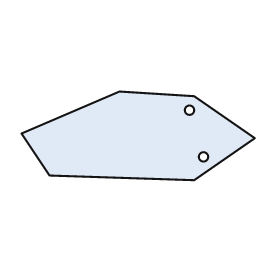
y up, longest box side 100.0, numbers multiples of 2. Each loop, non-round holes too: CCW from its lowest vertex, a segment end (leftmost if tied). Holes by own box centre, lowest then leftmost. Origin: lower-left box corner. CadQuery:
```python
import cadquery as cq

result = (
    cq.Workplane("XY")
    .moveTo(74.0, 0.0)
    .lineTo(100.0, 18.0)
    .lineTo(74.0, 36.0)
    .lineTo(42.0, 38.0)
    .lineTo(0.0, 20.0)
    .lineTo(12.0, 2.0)
    .close()
    .moveTo(78.0, 10.0)
    .circle(2.0)
    .moveTo(72.0, 30.0)
    .circle(2.0)
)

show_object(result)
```